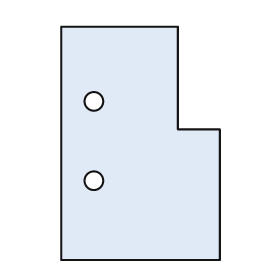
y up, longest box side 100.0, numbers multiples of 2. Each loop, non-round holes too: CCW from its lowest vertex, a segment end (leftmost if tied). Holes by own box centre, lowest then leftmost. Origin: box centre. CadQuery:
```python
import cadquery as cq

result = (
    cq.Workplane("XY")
    .moveTo(-34.0, -50.0)
    .lineTo(34.0, -50.0)
    .lineTo(34.0, 6.0)
    .lineTo(16.0, 6.0)
    .lineTo(16.0, 50.0)
    .lineTo(-34.0, 50.0)
    .close()
    .moveTo(-20.0, -16.0)
    .circle(4.0)
    .moveTo(-20.0, 18.0)
    .circle(4.0)
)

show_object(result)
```